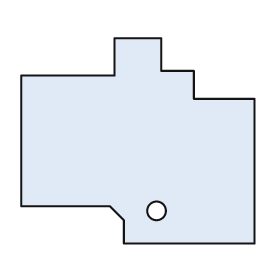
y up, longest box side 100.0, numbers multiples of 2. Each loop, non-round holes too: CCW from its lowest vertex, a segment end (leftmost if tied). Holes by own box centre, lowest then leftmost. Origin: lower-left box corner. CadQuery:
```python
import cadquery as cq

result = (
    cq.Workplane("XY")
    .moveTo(44.0, 0.0)
    .lineTo(100.0, 0.0)
    .lineTo(100.0, 62.0)
    .lineTo(74.0, 62.0)
    .lineTo(74.0, 74.0)
    .lineTo(60.0, 74.0)
    .lineTo(60.0, 88.0)
    .lineTo(40.0, 88.0)
    .lineTo(40.0, 72.0)
    .lineTo(0.0, 72.0)
    .lineTo(0.0, 16.0)
    .lineTo(38.0, 16.0)
    .lineTo(44.0, 10.0)
    .close()
    .moveTo(58.0, 14.0)
    .circle(4.0)
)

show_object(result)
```